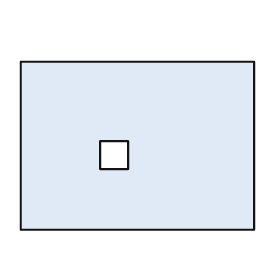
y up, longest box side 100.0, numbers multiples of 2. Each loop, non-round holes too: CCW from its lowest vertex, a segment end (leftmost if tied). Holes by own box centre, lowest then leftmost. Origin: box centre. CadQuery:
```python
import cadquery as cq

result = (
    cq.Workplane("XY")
    .moveTo(-50.0, -36.0)
    .lineTo(50.0, -36.0)
    .lineTo(50.0, 36.0)
    .lineTo(-50.0, 36.0)
    .close()
    .moveTo(-16.0, -10.0)
    .lineTo(-4.0, -10.0)
    .lineTo(-4.0, 2.0)
    .lineTo(-16.0, 2.0)
    .close()
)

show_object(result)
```